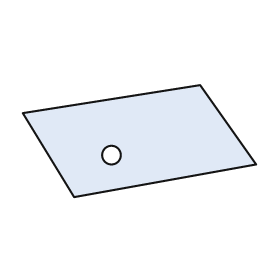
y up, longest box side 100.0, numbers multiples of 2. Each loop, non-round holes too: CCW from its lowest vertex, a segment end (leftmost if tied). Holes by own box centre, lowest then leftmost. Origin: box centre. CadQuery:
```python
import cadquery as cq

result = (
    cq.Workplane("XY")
    .moveTo(-28.0, -24.0)
    .lineTo(50.0, -10.0)
    .lineTo(26.0, 24.0)
    .lineTo(-50.0, 12.0)
    .close()
    .moveTo(-12.0, -6.0)
    .circle(4.0)
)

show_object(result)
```